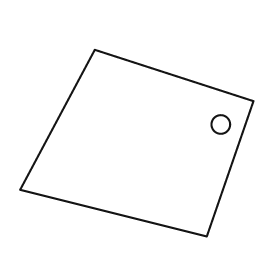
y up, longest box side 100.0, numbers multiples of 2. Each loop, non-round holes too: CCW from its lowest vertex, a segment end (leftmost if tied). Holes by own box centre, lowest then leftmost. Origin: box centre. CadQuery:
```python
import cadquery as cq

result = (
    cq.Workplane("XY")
    .moveTo(30.0, -40.0)
    .lineTo(50.0, 18.0)
    .lineTo(-18.0, 40.0)
    .lineTo(-50.0, -20.0)
    .close()
    .moveTo(36.0, 8.0)
    .circle(4.0)
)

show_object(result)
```